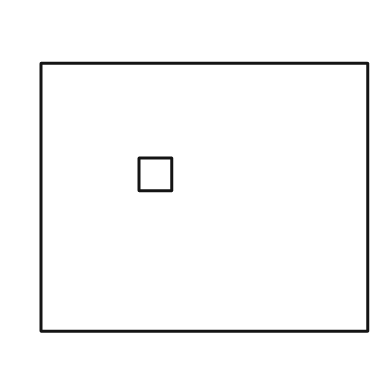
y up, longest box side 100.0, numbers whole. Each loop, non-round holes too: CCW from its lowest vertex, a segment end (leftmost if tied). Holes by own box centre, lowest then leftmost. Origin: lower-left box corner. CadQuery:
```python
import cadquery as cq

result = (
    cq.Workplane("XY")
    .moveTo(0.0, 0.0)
    .lineTo(100.0, 0.0)
    .lineTo(100.0, 82.0)
    .lineTo(0.0, 82.0)
    .close()
    .moveTo(30.0, 43.0)
    .lineTo(40.0, 43.0)
    .lineTo(40.0, 53.0)
    .lineTo(30.0, 53.0)
    .close()
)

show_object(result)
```